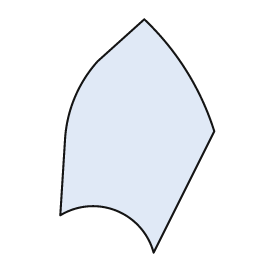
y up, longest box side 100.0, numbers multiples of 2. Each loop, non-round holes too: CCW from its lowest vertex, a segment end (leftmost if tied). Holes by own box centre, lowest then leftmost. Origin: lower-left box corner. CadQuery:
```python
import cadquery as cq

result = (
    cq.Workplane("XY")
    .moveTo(40.0, 0.0)
    .lineTo(66.0, 52.0)
    .threePointArc((54.0, 78.0), (36.0, 100.0))
    .lineTo(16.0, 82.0)
    .threePointArc((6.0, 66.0), (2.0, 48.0))
    .lineTo(0.0, 16.0)
    .threePointArc((24.0, 18.0), (40.0, 0.0))
    .close()
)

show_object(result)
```